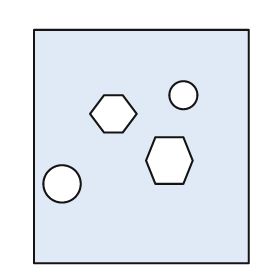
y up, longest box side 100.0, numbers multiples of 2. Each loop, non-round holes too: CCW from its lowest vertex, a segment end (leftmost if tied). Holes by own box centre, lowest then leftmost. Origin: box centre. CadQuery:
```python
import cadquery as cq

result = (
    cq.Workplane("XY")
    .moveTo(-46.0, -50.0)
    .lineTo(46.0, -50.0)
    .lineTo(46.0, 50.0)
    .lineTo(-46.0, 50.0)
    .close()
    .moveTo(-34.0, -16.0)
    .circle(8.0)
    .moveTo(6.0, -16.0)
    .lineTo(18.0, -16.0)
    .lineTo(22.0, -6.0)
    .lineTo(18.0, 4.0)
    .lineTo(6.0, 4.0)
    .lineTo(2.0, -6.0)
    .close()
    .moveTo(-16.0, 6.0)
    .lineTo(-8.0, 6.0)
    .lineTo(-2.0, 14.0)
    .lineTo(-8.0, 22.0)
    .lineTo(-16.0, 22.0)
    .lineTo(-22.0, 14.0)
    .close()
    .moveTo(18.0, 22.0)
    .circle(6.0)
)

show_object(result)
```